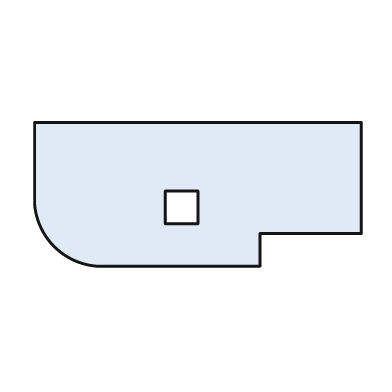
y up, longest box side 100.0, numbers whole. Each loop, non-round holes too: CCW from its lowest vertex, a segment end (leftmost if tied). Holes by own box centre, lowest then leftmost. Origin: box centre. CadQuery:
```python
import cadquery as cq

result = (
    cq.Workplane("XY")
    .moveTo(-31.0, -22.0)
    .lineTo(19.0, -22.0)
    .lineTo(19.0, -12.0)
    .lineTo(50.0, -12.0)
    .lineTo(50.0, 22.0)
    .lineTo(-50.0, 22.0)
    .lineTo(-50.0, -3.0)
    .threePointArc((-44.0, -16.0), (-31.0, -22.0))
    .close()
    .moveTo(-10.0, -9.0)
    .lineTo(0.0, -9.0)
    .lineTo(0.0, 1.0)
    .lineTo(-10.0, 1.0)
    .close()
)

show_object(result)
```